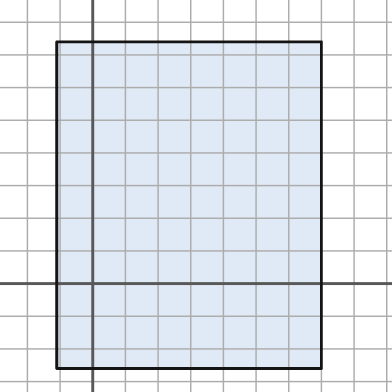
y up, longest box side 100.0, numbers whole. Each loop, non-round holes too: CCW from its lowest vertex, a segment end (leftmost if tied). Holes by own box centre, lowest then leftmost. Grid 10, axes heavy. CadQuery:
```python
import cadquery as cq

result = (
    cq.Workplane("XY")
    .moveTo(-11.0, -26.0)
    .lineTo(70.0, -26.0)
    .lineTo(70.0, 74.0)
    .lineTo(-11.0, 74.0)
    .close()
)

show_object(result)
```